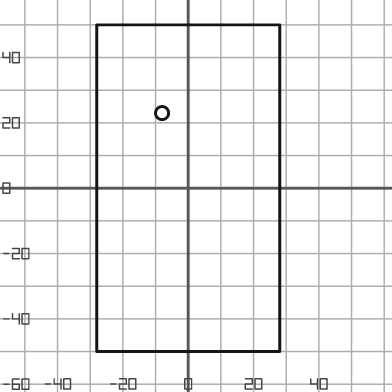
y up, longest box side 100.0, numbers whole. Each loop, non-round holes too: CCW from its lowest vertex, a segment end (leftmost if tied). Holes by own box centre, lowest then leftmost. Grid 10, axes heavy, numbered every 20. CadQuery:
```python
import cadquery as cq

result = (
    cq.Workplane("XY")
    .moveTo(-28.0, -50.0)
    .lineTo(28.0, -50.0)
    .lineTo(28.0, 50.0)
    .lineTo(-28.0, 50.0)
    .close()
    .moveTo(-8.0, 23.0)
    .circle(2.0)
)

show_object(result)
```